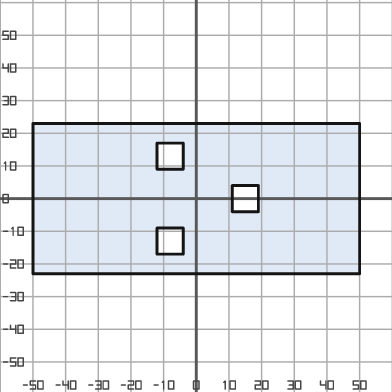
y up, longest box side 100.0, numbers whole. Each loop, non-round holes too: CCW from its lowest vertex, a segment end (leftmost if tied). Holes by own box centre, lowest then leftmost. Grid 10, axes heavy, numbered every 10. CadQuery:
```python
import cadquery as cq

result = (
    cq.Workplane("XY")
    .moveTo(-50.0, -23.0)
    .lineTo(50.0, -23.0)
    .lineTo(50.0, 23.0)
    .lineTo(-50.0, 23.0)
    .close()
    .moveTo(-12.0, -17.0)
    .lineTo(-4.0, -17.0)
    .lineTo(-4.0, -9.0)
    .lineTo(-12.0, -9.0)
    .close()
    .moveTo(11.0, -4.0)
    .lineTo(19.0, -4.0)
    .lineTo(19.0, 4.0)
    .lineTo(11.0, 4.0)
    .close()
    .moveTo(-12.0, 9.0)
    .lineTo(-4.0, 9.0)
    .lineTo(-4.0, 17.0)
    .lineTo(-12.0, 17.0)
    .close()
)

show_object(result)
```